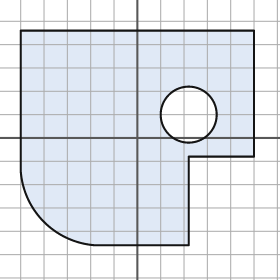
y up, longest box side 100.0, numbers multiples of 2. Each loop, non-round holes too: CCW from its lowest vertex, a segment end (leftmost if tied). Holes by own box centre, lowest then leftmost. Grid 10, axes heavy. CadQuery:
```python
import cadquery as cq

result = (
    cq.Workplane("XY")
    .moveTo(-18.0, -46.0)
    .lineTo(22.0, -46.0)
    .lineTo(22.0, -8.0)
    .lineTo(50.0, -8.0)
    .lineTo(50.0, 46.0)
    .lineTo(-50.0, 46.0)
    .lineTo(-50.0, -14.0)
    .threePointArc((-40.0, -36.0), (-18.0, -46.0))
    .close()
    .moveTo(22.0, 10.0)
    .circle(12.0)
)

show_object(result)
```